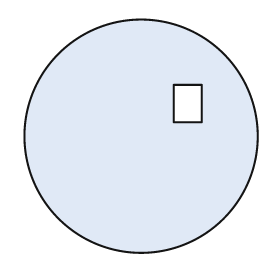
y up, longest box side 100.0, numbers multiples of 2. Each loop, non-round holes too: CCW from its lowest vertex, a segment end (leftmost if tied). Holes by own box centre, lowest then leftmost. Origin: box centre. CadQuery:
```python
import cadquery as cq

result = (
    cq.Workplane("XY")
    .moveTo(0.0, 0.0)
    .circle(50.0)
    .moveTo(14.0, 6.0)
    .lineTo(26.0, 6.0)
    .lineTo(26.0, 22.0)
    .lineTo(14.0, 22.0)
    .close()
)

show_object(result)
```